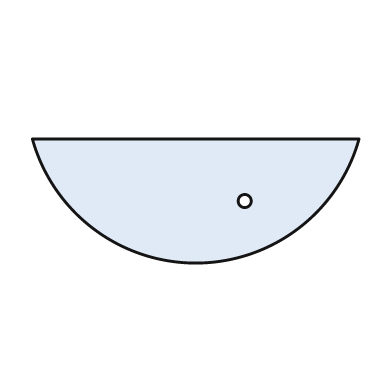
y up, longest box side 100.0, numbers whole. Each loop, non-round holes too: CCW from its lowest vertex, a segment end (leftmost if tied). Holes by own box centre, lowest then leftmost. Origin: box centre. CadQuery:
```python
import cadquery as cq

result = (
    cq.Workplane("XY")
    .moveTo(-50.0, 19.0)
    .threePointArc((0.0, -19.0), (50.0, 19.0))
    .close()
    .moveTo(15.0, 0.0)
    .circle(2.0)
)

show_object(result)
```